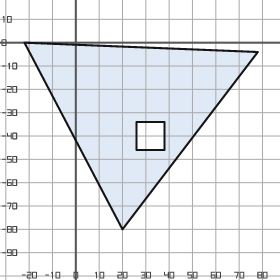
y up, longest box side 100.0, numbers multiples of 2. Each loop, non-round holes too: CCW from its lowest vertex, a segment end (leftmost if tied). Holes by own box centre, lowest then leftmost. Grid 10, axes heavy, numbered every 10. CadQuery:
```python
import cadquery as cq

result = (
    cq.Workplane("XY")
    .moveTo(20.0, -80.0)
    .lineTo(78.0, -4.0)
    .lineTo(-22.0, 0.0)
    .close()
    .moveTo(26.0, -46.0)
    .lineTo(38.0, -46.0)
    .lineTo(38.0, -34.0)
    .lineTo(26.0, -34.0)
    .close()
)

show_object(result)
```